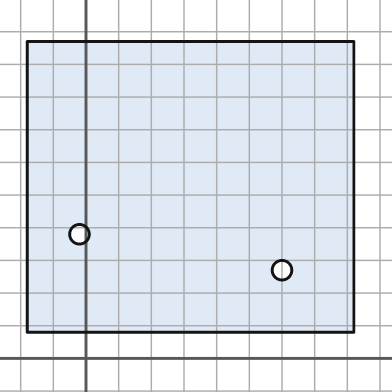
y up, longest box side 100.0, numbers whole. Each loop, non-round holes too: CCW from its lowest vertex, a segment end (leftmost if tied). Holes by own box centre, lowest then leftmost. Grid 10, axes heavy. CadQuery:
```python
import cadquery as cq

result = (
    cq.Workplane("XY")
    .moveTo(-18.0, 8.0)
    .lineTo(82.0, 8.0)
    .lineTo(82.0, 97.0)
    .lineTo(-18.0, 97.0)
    .close()
    .moveTo(60.0, 27.0)
    .circle(3.0)
    .moveTo(-2.0, 38.0)
    .circle(3.0)
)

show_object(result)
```